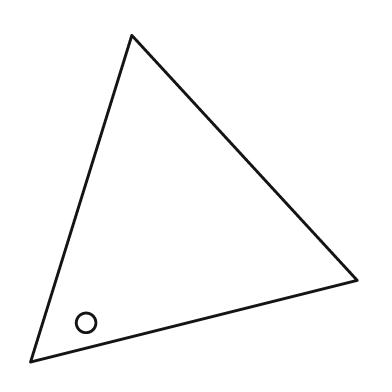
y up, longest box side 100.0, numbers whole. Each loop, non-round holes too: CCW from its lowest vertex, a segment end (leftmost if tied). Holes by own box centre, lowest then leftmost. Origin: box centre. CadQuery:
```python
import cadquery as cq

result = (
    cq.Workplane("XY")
    .moveTo(-50.0, -50.0)
    .lineTo(50.0, -25.0)
    .lineTo(-19.0, 50.0)
    .close()
    .moveTo(-33.0, -38.0)
    .circle(3.0)
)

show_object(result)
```